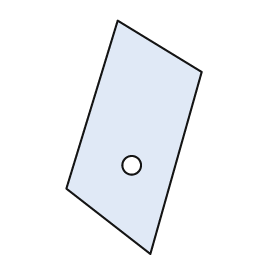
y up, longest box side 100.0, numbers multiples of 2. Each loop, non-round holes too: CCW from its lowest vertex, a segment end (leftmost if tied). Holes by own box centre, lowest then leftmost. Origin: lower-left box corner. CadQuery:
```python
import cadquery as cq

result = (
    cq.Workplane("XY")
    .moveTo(36.0, 0.0)
    .lineTo(58.0, 78.0)
    .lineTo(22.0, 100.0)
    .lineTo(0.0, 28.0)
    .close()
    .moveTo(28.0, 38.0)
    .circle(4.0)
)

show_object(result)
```